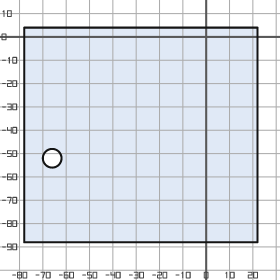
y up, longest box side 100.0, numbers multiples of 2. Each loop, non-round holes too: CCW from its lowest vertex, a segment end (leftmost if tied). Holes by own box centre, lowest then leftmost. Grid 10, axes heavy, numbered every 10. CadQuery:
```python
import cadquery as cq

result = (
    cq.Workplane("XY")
    .moveTo(-78.0, -88.0)
    .lineTo(22.0, -88.0)
    .lineTo(22.0, 4.0)
    .lineTo(-78.0, 4.0)
    .close()
    .moveTo(-66.0, -52.0)
    .circle(4.0)
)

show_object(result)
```